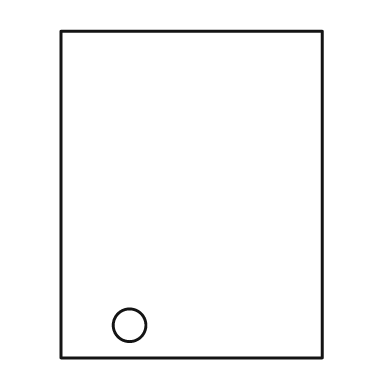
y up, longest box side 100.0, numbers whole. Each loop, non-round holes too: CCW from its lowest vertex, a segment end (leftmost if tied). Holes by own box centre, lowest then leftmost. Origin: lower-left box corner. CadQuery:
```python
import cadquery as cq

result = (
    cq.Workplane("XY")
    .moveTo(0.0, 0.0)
    .lineTo(80.0, 0.0)
    .lineTo(80.0, 100.0)
    .lineTo(0.0, 100.0)
    .close()
    .moveTo(21.0, 10.0)
    .circle(5.0)
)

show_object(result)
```